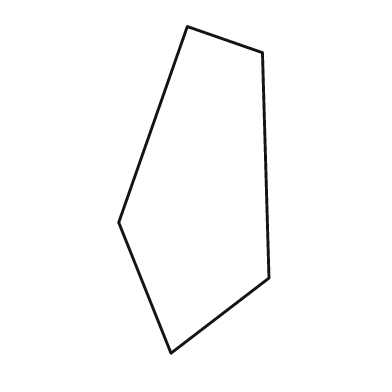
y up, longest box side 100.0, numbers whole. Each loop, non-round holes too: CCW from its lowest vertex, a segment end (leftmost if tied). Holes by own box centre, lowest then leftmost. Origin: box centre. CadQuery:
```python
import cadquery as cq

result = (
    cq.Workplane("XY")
    .moveTo(-7.0, -50.0)
    .lineTo(23.0, -27.0)
    .lineTo(21.0, 42.0)
    .lineTo(-2.0, 50.0)
    .lineTo(-23.0, -10.0)
    .close()
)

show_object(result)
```